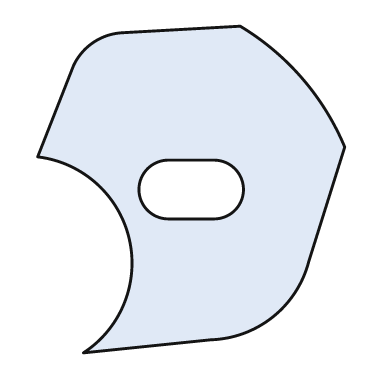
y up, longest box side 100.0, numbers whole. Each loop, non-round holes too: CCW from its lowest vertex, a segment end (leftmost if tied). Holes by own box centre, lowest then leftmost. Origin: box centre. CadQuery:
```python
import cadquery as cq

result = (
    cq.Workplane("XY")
    .moveTo(-33.0, -50.0)
    .lineTo(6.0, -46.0)
    .threePointArc((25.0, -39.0), (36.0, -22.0))
    .lineTo(47.0, 13.0)
    .threePointArc((34.0, 34.0), (15.0, 50.0))
    .lineTo(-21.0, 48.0)
    .threePointArc((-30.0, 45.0), (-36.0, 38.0))
    .lineTo(-47.0, 10.0)
    .threePointArc((-19.0, -15.0), (-33.0, -50.0))
    .close()
    .moveTo(-7.0, -9.0)
    .lineTo(7.0, -9.0)
    .threePointArc((16.0, 0.0), (7.0, 9.0))
    .lineTo(-7.0, 9.0)
    .threePointArc((-16.0, 0.0), (-7.0, -9.0))
    .close()
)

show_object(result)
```